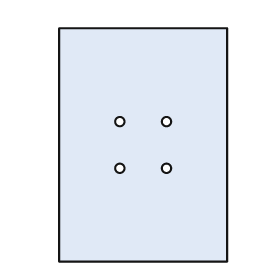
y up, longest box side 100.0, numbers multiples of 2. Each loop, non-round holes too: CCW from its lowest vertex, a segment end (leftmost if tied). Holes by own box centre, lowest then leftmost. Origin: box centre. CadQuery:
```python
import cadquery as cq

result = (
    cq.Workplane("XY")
    .moveTo(-36.0, -50.0)
    .lineTo(36.0, -50.0)
    .lineTo(36.0, 50.0)
    .lineTo(-36.0, 50.0)
    .close()
    .moveTo(-10.0, -10.0)
    .circle(2.0)
    .moveTo(10.0, -10.0)
    .circle(2.0)
    .moveTo(-10.0, 10.0)
    .circle(2.0)
    .moveTo(10.0, 10.0)
    .circle(2.0)
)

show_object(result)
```